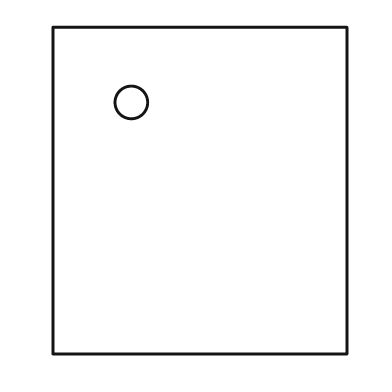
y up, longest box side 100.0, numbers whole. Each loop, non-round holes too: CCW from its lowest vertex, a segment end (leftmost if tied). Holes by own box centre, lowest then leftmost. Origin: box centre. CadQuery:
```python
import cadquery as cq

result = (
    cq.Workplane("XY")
    .moveTo(-45.0, -50.0)
    .lineTo(45.0, -50.0)
    .lineTo(45.0, 50.0)
    .lineTo(-45.0, 50.0)
    .close()
    .moveTo(-21.0, 27.0)
    .circle(5.0)
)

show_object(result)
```